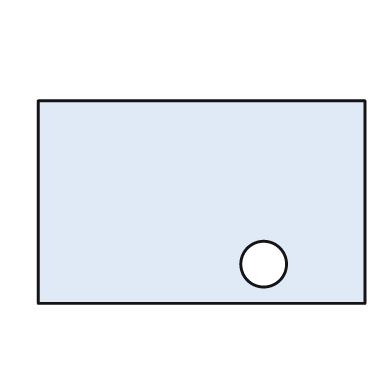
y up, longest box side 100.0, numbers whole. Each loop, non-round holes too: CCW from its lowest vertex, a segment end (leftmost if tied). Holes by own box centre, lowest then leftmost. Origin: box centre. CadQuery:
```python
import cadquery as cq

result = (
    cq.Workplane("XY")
    .moveTo(-50.0, -31.0)
    .lineTo(50.0, -31.0)
    .lineTo(50.0, 31.0)
    .lineTo(-50.0, 31.0)
    .close()
    .moveTo(19.0, -19.0)
    .circle(7.0)
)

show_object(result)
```